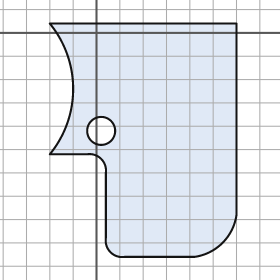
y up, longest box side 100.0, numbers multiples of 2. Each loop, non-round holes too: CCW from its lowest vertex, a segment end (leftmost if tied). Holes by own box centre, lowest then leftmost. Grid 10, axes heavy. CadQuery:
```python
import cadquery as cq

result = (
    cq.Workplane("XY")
    .moveTo(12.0, -96.0)
    .lineTo(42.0, -96.0)
    .threePointArc((54.0, -90.0), (60.0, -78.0))
    .lineTo(60.0, 4.0)
    .lineTo(-20.0, 4.0)
    .threePointArc((-10.0, -24.0), (-20.0, -52.0))
    .lineTo(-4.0, -52.0)
    .threePointArc((2.0, -54.0), (4.0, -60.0))
    .lineTo(4.0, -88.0)
    .threePointArc((6.0, -94.0), (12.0, -96.0))
    .close()
    .moveTo(2.0, -42.0)
    .circle(6.0)
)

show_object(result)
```